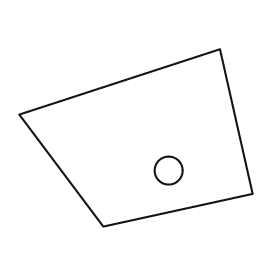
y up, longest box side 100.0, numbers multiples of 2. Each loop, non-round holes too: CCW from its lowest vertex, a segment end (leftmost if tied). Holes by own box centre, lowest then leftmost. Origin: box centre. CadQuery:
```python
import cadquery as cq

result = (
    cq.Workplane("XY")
    .moveTo(-14.0, -38.0)
    .lineTo(50.0, -24.0)
    .lineTo(36.0, 38.0)
    .lineTo(-50.0, 10.0)
    .close()
    .moveTo(14.0, -14.0)
    .circle(6.0)
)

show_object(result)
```